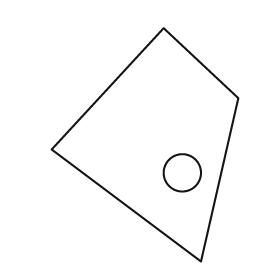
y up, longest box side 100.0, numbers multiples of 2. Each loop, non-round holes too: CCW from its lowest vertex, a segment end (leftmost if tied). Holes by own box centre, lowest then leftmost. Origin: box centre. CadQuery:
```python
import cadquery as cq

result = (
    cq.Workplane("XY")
    .moveTo(24.0, -50.0)
    .lineTo(40.0, 20.0)
    .lineTo(8.0, 50.0)
    .lineTo(-40.0, -2.0)
    .close()
    .moveTo(16.0, -12.0)
    .circle(8.0)
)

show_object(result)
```